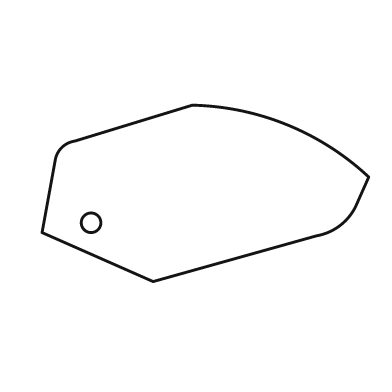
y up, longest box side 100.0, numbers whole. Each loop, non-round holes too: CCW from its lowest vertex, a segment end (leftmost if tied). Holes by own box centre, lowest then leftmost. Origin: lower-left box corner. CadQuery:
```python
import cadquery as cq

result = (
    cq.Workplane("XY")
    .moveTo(34.0, 0.0)
    .lineTo(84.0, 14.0)
    .threePointArc((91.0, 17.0), (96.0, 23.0))
    .lineTo(100.0, 32.0)
    .threePointArc((75.0, 48.0), (46.0, 54.0))
    .lineTo(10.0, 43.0)
    .threePointArc((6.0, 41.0), (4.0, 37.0))
    .lineTo(0.0, 15.0)
    .close()
    .moveTo(15.0, 18.0)
    .circle(3.0)
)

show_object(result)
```